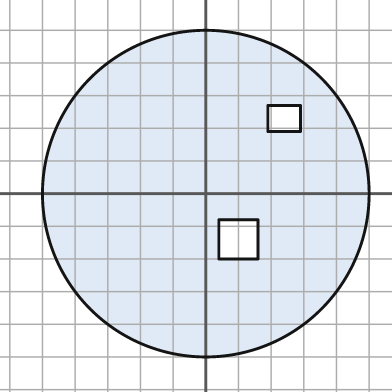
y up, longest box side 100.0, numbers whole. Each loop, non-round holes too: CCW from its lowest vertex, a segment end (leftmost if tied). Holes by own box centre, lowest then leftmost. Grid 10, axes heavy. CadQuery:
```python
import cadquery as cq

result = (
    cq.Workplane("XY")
    .moveTo(0.0, 0.0)
    .circle(50.0)
    .moveTo(4.0, -20.0)
    .lineTo(16.0, -20.0)
    .lineTo(16.0, -8.0)
    .lineTo(4.0, -8.0)
    .close()
    .moveTo(19.0, 19.0)
    .lineTo(29.0, 19.0)
    .lineTo(29.0, 27.0)
    .lineTo(19.0, 27.0)
    .close()
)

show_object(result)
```